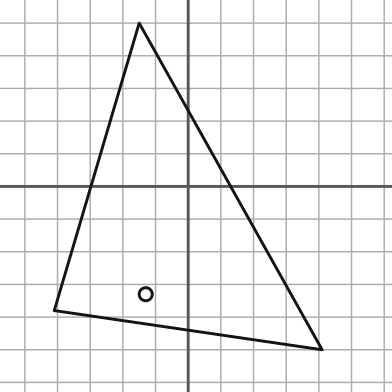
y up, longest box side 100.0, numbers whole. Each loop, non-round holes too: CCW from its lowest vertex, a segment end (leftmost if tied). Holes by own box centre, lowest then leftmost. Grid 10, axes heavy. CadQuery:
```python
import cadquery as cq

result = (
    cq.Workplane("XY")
    .moveTo(41.0, -50.0)
    .lineTo(-15.0, 50.0)
    .lineTo(-41.0, -38.0)
    .close()
    .moveTo(-13.0, -33.0)
    .circle(2.0)
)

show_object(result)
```